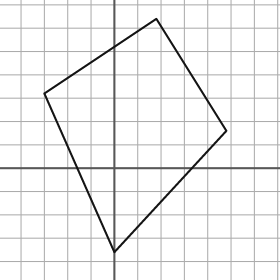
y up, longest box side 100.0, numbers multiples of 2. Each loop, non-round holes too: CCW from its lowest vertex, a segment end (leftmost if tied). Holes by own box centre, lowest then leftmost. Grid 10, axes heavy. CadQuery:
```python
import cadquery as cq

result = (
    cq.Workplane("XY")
    .moveTo(0.0, -36.0)
    .lineTo(48.0, 16.0)
    .lineTo(18.0, 64.0)
    .lineTo(-30.0, 32.0)
    .close()
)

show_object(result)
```